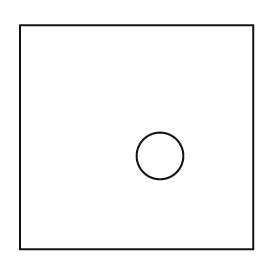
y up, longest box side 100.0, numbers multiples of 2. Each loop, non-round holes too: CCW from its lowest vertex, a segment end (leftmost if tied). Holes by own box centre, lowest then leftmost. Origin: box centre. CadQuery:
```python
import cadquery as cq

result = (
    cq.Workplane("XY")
    .moveTo(-50.0, -48.0)
    .lineTo(50.0, -48.0)
    .lineTo(50.0, 48.0)
    .lineTo(-50.0, 48.0)
    .close()
    .moveTo(10.0, -8.0)
    .circle(10.0)
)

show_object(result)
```